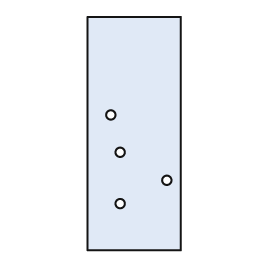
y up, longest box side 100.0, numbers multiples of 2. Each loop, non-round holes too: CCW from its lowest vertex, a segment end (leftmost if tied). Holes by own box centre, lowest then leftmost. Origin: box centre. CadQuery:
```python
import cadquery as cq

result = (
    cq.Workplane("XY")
    .moveTo(-20.0, -50.0)
    .lineTo(20.0, -50.0)
    .lineTo(20.0, 50.0)
    .lineTo(-20.0, 50.0)
    .close()
    .moveTo(-6.0, -30.0)
    .circle(2.0)
    .moveTo(14.0, -20.0)
    .circle(2.0)
    .moveTo(-6.0, -8.0)
    .circle(2.0)
    .moveTo(-10.0, 8.0)
    .circle(2.0)
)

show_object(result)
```